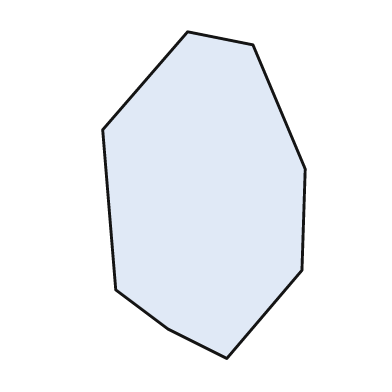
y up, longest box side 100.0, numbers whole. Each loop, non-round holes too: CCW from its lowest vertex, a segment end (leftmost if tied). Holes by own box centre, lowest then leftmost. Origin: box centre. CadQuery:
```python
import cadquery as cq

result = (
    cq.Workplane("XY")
    .moveTo(7.0, -50.0)
    .lineTo(30.0, -23.0)
    .lineTo(31.0, 8.0)
    .lineTo(15.0, 46.0)
    .lineTo(-5.0, 50.0)
    .lineTo(-31.0, 20.0)
    .lineTo(-27.0, -29.0)
    .lineTo(-11.0, -41.0)
    .close()
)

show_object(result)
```